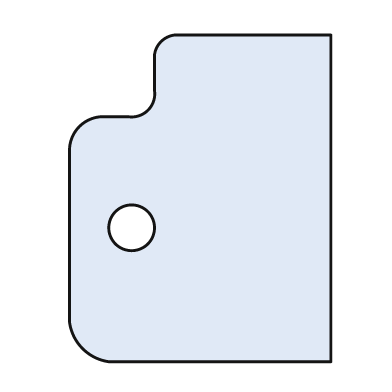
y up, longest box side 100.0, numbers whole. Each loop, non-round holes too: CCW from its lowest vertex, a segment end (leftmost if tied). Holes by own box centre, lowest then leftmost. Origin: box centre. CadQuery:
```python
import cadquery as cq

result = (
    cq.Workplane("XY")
    .moveTo(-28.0, -50.0)
    .lineTo(40.0, -50.0)
    .lineTo(40.0, 50.0)
    .lineTo(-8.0, 50.0)
    .threePointArc((-12.0, 48.0), (-14.0, 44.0))
    .lineTo(-14.0, 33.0)
    .threePointArc((-16.0, 27.0), (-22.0, 25.0))
    .lineTo(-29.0, 25.0)
    .threePointArc((-37.0, 22.0), (-40.0, 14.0))
    .lineTo(-40.0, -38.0)
    .threePointArc((-36.0, -46.0), (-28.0, -50.0))
    .close()
    .moveTo(-21.0, -9.0)
    .circle(7.0)
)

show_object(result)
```